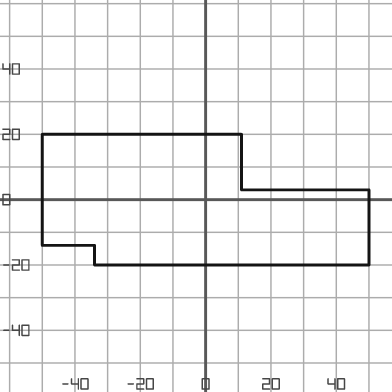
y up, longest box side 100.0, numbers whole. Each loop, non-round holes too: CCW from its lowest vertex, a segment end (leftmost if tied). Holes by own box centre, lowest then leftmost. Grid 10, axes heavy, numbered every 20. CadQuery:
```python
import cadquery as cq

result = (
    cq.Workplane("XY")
    .moveTo(-34.0, -20.0)
    .lineTo(50.0, -20.0)
    .lineTo(50.0, 3.0)
    .lineTo(11.0, 3.0)
    .lineTo(11.0, 20.0)
    .lineTo(-50.0, 20.0)
    .lineTo(-50.0, -14.0)
    .lineTo(-34.0, -14.0)
    .close()
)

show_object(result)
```